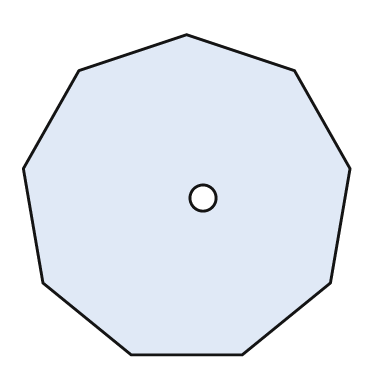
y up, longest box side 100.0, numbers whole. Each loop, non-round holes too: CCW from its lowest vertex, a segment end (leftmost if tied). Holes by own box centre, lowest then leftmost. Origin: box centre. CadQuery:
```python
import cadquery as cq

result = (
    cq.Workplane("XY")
    .moveTo(-17.0, -49.0)
    .lineTo(17.0, -49.0)
    .lineTo(44.0, -27.0)
    .lineTo(50.0, 8.0)
    .lineTo(33.0, 38.0)
    .lineTo(0.0, 49.0)
    .lineTo(-33.0, 38.0)
    .lineTo(-50.0, 8.0)
    .lineTo(-44.0, -27.0)
    .close()
    .moveTo(5.0, -1.0)
    .circle(4.0)
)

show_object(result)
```